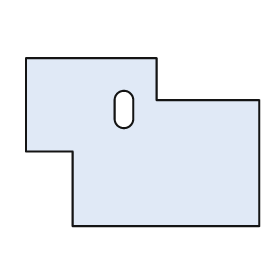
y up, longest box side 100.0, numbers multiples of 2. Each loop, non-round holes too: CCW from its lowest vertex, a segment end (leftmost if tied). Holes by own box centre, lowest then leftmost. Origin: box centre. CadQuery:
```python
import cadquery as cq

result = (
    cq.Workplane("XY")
    .moveTo(-30.0, -36.0)
    .lineTo(50.0, -36.0)
    .lineTo(50.0, 18.0)
    .lineTo(6.0, 18.0)
    .lineTo(6.0, 36.0)
    .lineTo(-50.0, 36.0)
    .lineTo(-50.0, -4.0)
    .lineTo(-30.0, -4.0)
    .close()
    .moveTo(-12.0, 10.0)
    .threePointArc((-8.0, 6.0), (-4.0, 10.0))
    .lineTo(-4.0, 18.0)
    .threePointArc((-8.0, 22.0), (-12.0, 18.0))
    .close()
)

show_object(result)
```